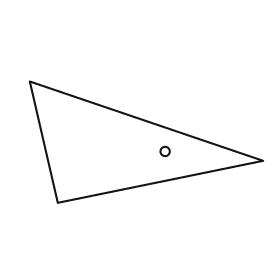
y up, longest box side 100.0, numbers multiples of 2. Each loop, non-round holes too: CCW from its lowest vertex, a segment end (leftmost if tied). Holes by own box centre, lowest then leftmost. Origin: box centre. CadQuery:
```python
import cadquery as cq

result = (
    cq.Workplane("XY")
    .moveTo(-38.0, -26.0)
    .lineTo(50.0, -8.0)
    .lineTo(-50.0, 26.0)
    .close()
    .moveTo(8.0, -4.0)
    .circle(2.0)
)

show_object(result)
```